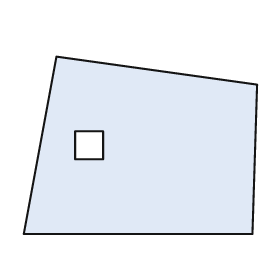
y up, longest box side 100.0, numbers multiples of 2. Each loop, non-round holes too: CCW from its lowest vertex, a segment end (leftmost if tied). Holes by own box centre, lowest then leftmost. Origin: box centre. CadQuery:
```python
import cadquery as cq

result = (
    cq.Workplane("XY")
    .moveTo(-50.0, -38.0)
    .lineTo(48.0, -38.0)
    .lineTo(50.0, 26.0)
    .lineTo(-36.0, 38.0)
    .close()
    .moveTo(-28.0, -6.0)
    .lineTo(-16.0, -6.0)
    .lineTo(-16.0, 6.0)
    .lineTo(-28.0, 6.0)
    .close()
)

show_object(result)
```